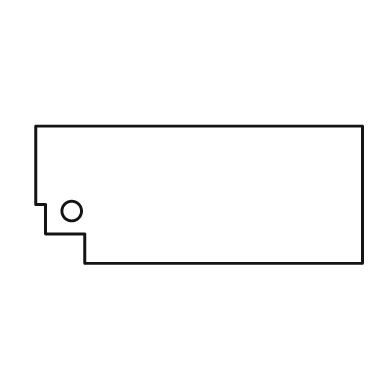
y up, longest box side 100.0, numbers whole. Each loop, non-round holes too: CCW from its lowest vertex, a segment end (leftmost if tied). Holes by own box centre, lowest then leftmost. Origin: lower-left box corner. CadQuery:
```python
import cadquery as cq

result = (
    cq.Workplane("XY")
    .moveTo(15.0, 0.0)
    .lineTo(100.0, 0.0)
    .lineTo(100.0, 42.0)
    .lineTo(0.0, 42.0)
    .lineTo(0.0, 18.0)
    .lineTo(3.0, 18.0)
    .lineTo(3.0, 9.0)
    .lineTo(15.0, 9.0)
    .close()
    .moveTo(11.0, 16.0)
    .circle(3.0)
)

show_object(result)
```